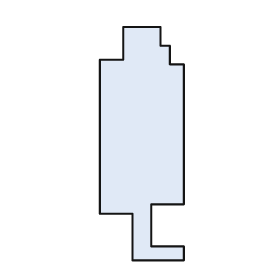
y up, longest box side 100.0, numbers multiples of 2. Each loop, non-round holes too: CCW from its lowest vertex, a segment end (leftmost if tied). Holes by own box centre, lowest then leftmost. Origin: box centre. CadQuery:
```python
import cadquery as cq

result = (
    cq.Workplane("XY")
    .moveTo(-4.0, -50.0)
    .lineTo(18.0, -50.0)
    .lineTo(18.0, -44.0)
    .lineTo(4.0, -44.0)
    .lineTo(4.0, -26.0)
    .lineTo(18.0, -26.0)
    .lineTo(18.0, 34.0)
    .lineTo(12.0, 34.0)
    .lineTo(12.0, 42.0)
    .lineTo(8.0, 42.0)
    .lineTo(8.0, 50.0)
    .lineTo(-8.0, 50.0)
    .lineTo(-8.0, 36.0)
    .lineTo(-18.0, 36.0)
    .lineTo(-18.0, -30.0)
    .lineTo(-4.0, -30.0)
    .close()
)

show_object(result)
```